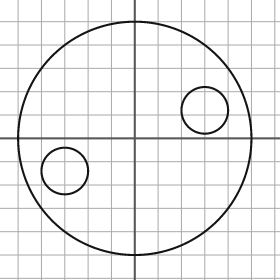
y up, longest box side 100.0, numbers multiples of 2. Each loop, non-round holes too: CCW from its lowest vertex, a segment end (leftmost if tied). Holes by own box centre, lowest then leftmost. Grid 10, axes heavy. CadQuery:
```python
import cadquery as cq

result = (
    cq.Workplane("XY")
    .moveTo(0.0, 0.0)
    .circle(50.0)
    .moveTo(-30.0, -14.0)
    .circle(10.0)
    .moveTo(30.0, 12.0)
    .circle(10.0)
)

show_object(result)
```